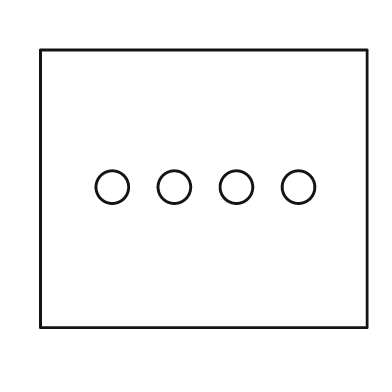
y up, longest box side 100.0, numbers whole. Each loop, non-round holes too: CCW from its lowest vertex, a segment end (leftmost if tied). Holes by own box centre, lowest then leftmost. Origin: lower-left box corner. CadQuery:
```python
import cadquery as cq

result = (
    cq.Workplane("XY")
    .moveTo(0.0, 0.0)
    .lineTo(100.0, 0.0)
    .lineTo(100.0, 85.0)
    .lineTo(0.0, 85.0)
    .close()
    .moveTo(22.0, 43.0)
    .circle(5.0)
    .moveTo(41.0, 43.0)
    .circle(5.0)
    .moveTo(60.0, 43.0)
    .circle(5.0)
    .moveTo(79.0, 43.0)
    .circle(5.0)
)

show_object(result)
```